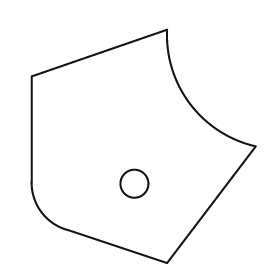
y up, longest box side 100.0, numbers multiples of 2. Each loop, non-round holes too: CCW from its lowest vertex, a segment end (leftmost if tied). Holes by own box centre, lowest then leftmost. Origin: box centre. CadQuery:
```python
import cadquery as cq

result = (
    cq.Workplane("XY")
    .moveTo(10.0, -50.0)
    .lineTo(48.0, 0.0)
    .threePointArc((20.0, 18.0), (10.0, 50.0))
    .lineTo(-48.0, 30.0)
    .lineTo(-48.0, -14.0)
    .threePointArc((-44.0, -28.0), (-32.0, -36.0))
    .close()
    .moveTo(-4.0, -16.0)
    .circle(6.0)
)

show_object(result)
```